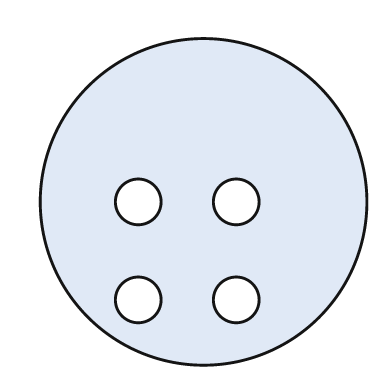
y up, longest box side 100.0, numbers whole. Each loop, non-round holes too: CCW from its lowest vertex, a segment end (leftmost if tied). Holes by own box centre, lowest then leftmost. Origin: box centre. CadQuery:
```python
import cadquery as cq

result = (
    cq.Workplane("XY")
    .moveTo(0.0, 0.0)
    .circle(50.0)
    .moveTo(-20.0, -30.0)
    .circle(7.0)
    .moveTo(10.0, -30.0)
    .circle(7.0)
    .moveTo(-20.0, 0.0)
    .circle(7.0)
    .moveTo(10.0, 0.0)
    .circle(7.0)
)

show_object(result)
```